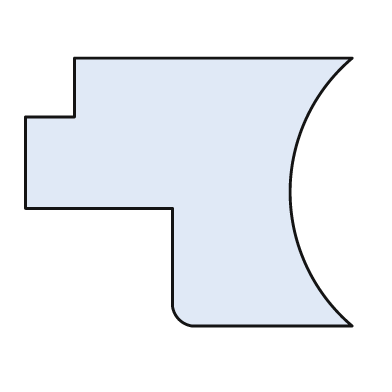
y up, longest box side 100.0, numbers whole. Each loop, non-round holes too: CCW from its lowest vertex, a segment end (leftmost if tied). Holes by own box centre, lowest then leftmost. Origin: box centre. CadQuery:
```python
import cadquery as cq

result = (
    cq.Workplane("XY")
    .moveTo(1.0, -41.0)
    .lineTo(50.0, -41.0)
    .threePointArc((31.0, 0.0), (50.0, 41.0))
    .lineTo(-35.0, 41.0)
    .lineTo(-35.0, 23.0)
    .lineTo(-50.0, 23.0)
    .lineTo(-50.0, -5.0)
    .lineTo(-5.0, -5.0)
    .lineTo(-5.0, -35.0)
    .threePointArc((-3.0, -39.0), (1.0, -41.0))
    .close()
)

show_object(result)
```